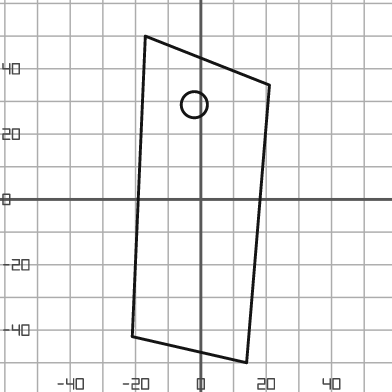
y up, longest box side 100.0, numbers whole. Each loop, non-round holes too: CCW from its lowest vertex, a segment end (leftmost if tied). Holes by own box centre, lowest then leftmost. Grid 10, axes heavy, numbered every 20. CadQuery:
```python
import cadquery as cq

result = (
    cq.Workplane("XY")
    .moveTo(14.0, -50.0)
    .lineTo(21.0, 35.0)
    .lineTo(-17.0, 50.0)
    .lineTo(-21.0, -42.0)
    .close()
    .moveTo(-2.0, 29.0)
    .circle(4.0)
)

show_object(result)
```